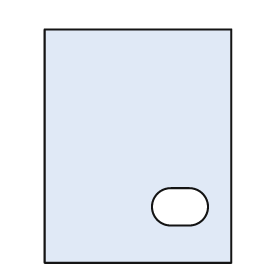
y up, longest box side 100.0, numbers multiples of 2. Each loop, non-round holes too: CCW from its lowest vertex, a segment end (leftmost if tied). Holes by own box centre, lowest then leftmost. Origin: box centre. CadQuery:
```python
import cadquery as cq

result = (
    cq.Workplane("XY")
    .moveTo(-40.0, -50.0)
    .lineTo(40.0, -50.0)
    .lineTo(40.0, 50.0)
    .lineTo(-40.0, 50.0)
    .close()
    .moveTo(14.0, -34.0)
    .lineTo(22.0, -34.0)
    .threePointArc((30.0, -26.0), (22.0, -18.0))
    .lineTo(14.0, -18.0)
    .threePointArc((6.0, -26.0), (14.0, -34.0))
    .close()
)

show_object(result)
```